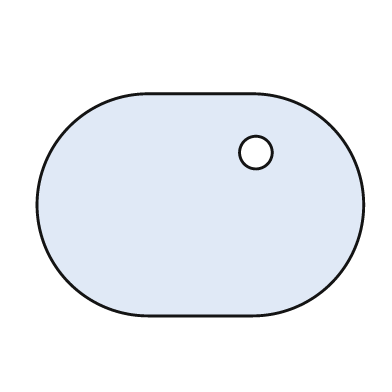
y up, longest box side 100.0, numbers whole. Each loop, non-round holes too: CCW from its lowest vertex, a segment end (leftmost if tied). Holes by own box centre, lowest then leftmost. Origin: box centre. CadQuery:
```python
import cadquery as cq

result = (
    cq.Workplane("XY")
    .moveTo(-16.0, -34.0)
    .lineTo(16.0, -34.0)
    .threePointArc((50.0, 0.0), (16.0, 34.0))
    .lineTo(-16.0, 34.0)
    .threePointArc((-50.0, 0.0), (-16.0, -34.0))
    .close()
    .moveTo(17.0, 16.0)
    .circle(5.0)
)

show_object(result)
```